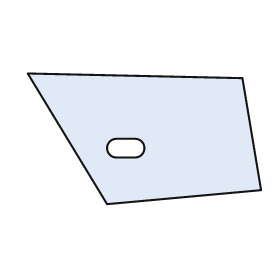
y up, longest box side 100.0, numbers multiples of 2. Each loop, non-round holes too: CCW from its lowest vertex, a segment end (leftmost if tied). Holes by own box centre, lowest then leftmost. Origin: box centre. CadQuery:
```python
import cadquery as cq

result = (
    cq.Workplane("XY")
    .moveTo(-16.0, -28.0)
    .lineTo(50.0, -22.0)
    .lineTo(42.0, 26.0)
    .lineTo(-50.0, 28.0)
    .close()
    .moveTo(-12.0, -8.0)
    .lineTo(-4.0, -8.0)
    .threePointArc((0.0, -4.0), (-4.0, 0.0))
    .lineTo(-12.0, 0.0)
    .threePointArc((-16.0, -4.0), (-12.0, -8.0))
    .close()
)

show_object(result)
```